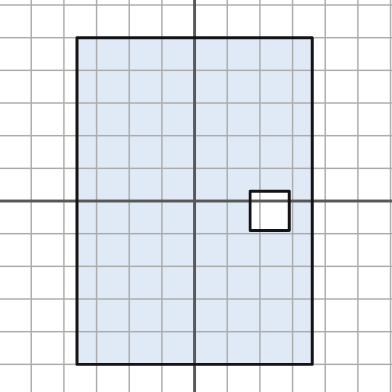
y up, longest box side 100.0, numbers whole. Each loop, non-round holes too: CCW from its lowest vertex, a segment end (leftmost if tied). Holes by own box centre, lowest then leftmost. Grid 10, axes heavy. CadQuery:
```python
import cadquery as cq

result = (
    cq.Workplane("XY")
    .moveTo(-36.0, -50.0)
    .lineTo(36.0, -50.0)
    .lineTo(36.0, 50.0)
    .lineTo(-36.0, 50.0)
    .close()
    .moveTo(17.0, -9.0)
    .lineTo(29.0, -9.0)
    .lineTo(29.0, 3.0)
    .lineTo(17.0, 3.0)
    .close()
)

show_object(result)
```